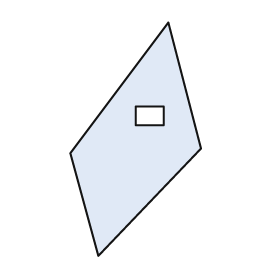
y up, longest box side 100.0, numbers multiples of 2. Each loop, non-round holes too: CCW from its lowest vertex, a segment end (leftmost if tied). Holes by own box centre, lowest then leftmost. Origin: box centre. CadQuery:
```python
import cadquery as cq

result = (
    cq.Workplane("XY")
    .moveTo(-16.0, -50.0)
    .lineTo(28.0, -4.0)
    .lineTo(14.0, 50.0)
    .lineTo(-28.0, -6.0)
    .close()
    .moveTo(0.0, 6.0)
    .lineTo(12.0, 6.0)
    .lineTo(12.0, 14.0)
    .lineTo(0.0, 14.0)
    .close()
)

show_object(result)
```